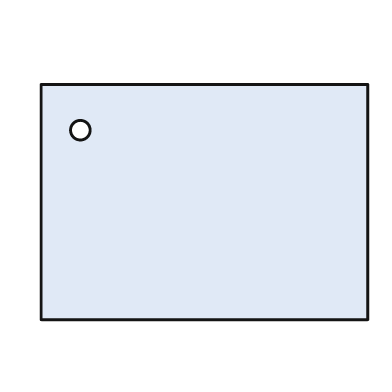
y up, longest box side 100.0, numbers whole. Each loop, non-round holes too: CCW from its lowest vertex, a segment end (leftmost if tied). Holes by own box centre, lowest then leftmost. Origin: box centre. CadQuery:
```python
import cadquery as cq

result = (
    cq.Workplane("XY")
    .moveTo(-50.0, -36.0)
    .lineTo(50.0, -36.0)
    .lineTo(50.0, 36.0)
    .lineTo(-50.0, 36.0)
    .close()
    .moveTo(-38.0, 22.0)
    .circle(3.0)
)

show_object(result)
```